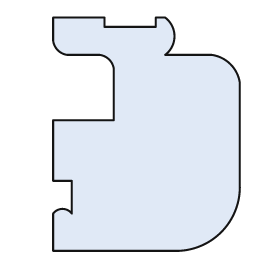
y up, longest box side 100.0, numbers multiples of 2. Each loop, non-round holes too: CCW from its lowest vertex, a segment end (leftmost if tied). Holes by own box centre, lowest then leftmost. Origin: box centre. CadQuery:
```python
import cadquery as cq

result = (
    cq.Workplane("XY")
    .moveTo(-40.0, -50.0)
    .lineTo(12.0, -50.0)
    .threePointArc((32.0, -42.0), (40.0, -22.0))
    .lineTo(40.0, 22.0)
    .threePointArc((36.0, 30.0), (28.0, 34.0))
    .lineTo(8.0, 34.0)
    .threePointArc((12.0, 42.0), (8.0, 50.0))
    .lineTo(4.0, 50.0)
    .lineTo(4.0, 46.0)
    .lineTo(-18.0, 46.0)
    .lineTo(-18.0, 50.0)
    .lineTo(-40.0, 50.0)
    .lineTo(-40.0, 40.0)
    .threePointArc((-38.0, 36.0), (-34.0, 34.0))
    .lineTo(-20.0, 34.0)
    .threePointArc((-16.0, 32.0), (-14.0, 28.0))
    .lineTo(-14.0, 6.0)
    .lineTo(-40.0, 6.0)
    .lineTo(-40.0, -20.0)
    .lineTo(-32.0, -20.0)
    .lineTo(-32.0, -34.0)
    .threePointArc((-36.0, -32.0), (-40.0, -34.0))
    .close()
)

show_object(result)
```